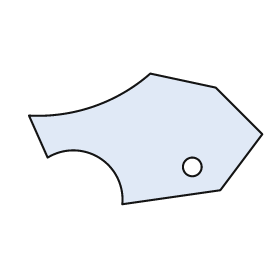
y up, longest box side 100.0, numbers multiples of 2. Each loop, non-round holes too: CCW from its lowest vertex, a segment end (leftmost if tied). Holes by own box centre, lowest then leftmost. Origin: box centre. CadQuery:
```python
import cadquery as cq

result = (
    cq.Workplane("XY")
    .moveTo(-10.0, -28.0)
    .lineTo(32.0, -22.0)
    .lineTo(50.0, 2.0)
    .lineTo(30.0, 22.0)
    .lineTo(2.0, 28.0)
    .threePointArc((-22.0, 14.0), (-50.0, 10.0))
    .lineTo(-42.0, -8.0)
    .threePointArc((-20.0, -8.0), (-10.0, -28.0))
    .close()
    .moveTo(20.0, -12.0)
    .circle(4.0)
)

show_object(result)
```